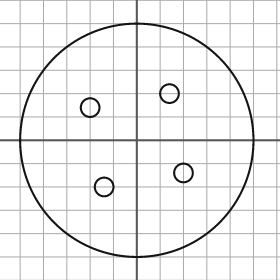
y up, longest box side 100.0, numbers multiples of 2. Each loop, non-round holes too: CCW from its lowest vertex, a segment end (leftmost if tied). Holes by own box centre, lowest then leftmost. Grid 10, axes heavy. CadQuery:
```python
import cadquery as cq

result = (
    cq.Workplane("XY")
    .moveTo(0.0, 0.0)
    .circle(50.0)
    .moveTo(-14.0, -20.0)
    .circle(4.0)
    .moveTo(20.0, -14.0)
    .circle(4.0)
    .moveTo(-20.0, 14.0)
    .circle(4.0)
    .moveTo(14.0, 20.0)
    .circle(4.0)
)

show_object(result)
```